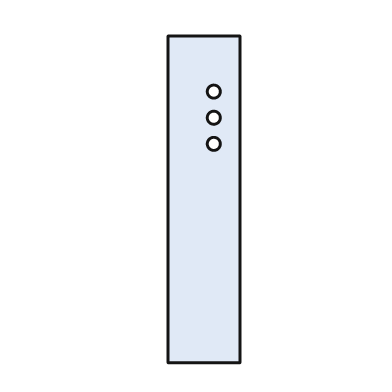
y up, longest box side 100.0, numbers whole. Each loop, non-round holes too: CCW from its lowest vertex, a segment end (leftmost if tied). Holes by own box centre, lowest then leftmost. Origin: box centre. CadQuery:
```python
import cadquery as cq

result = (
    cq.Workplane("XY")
    .moveTo(-11.0, -50.0)
    .lineTo(11.0, -50.0)
    .lineTo(11.0, 50.0)
    .lineTo(-11.0, 50.0)
    .close()
    .moveTo(3.0, 17.0)
    .circle(2.0)
    .moveTo(3.0, 25.0)
    .circle(2.0)
    .moveTo(3.0, 33.0)
    .circle(2.0)
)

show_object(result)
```